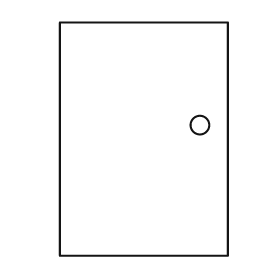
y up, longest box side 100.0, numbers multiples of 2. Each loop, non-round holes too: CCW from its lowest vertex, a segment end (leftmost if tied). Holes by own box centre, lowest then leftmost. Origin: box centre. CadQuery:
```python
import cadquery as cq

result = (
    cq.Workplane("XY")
    .moveTo(-36.0, -50.0)
    .lineTo(36.0, -50.0)
    .lineTo(36.0, 50.0)
    .lineTo(-36.0, 50.0)
    .close()
    .moveTo(24.0, 6.0)
    .circle(4.0)
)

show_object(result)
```